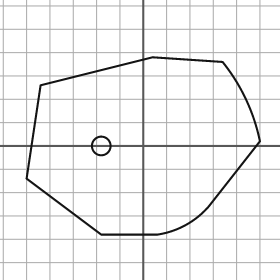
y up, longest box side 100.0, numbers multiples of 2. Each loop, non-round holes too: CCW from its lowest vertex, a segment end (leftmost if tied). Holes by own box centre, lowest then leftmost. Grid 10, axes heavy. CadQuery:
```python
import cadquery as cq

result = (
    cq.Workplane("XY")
    .moveTo(-18.0, -38.0)
    .lineTo(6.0, -38.0)
    .threePointArc((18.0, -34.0), (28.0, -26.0))
    .lineTo(50.0, 2.0)
    .threePointArc((44.0, 20.0), (34.0, 36.0))
    .lineTo(4.0, 38.0)
    .lineTo(-44.0, 26.0)
    .lineTo(-50.0, -14.0)
    .close()
    .moveTo(-18.0, 0.0)
    .circle(4.0)
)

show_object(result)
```